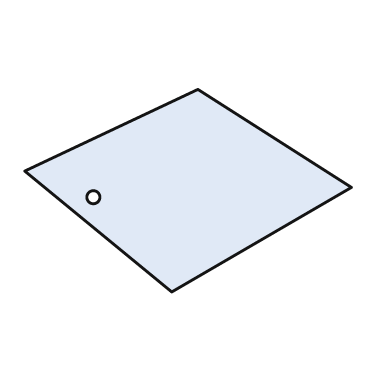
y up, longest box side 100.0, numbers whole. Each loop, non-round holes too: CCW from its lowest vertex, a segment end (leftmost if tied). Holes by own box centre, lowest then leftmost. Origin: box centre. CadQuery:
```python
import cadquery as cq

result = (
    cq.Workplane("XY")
    .moveTo(-5.0, -31.0)
    .lineTo(50.0, 1.0)
    .lineTo(3.0, 31.0)
    .lineTo(-50.0, 6.0)
    .close()
    .moveTo(-29.0, -2.0)
    .circle(2.0)
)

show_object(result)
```